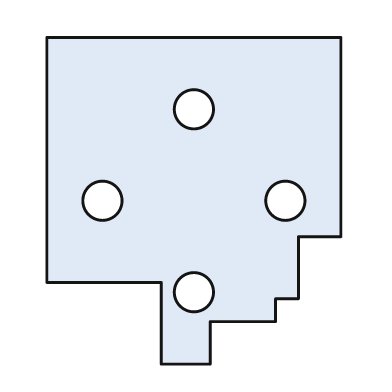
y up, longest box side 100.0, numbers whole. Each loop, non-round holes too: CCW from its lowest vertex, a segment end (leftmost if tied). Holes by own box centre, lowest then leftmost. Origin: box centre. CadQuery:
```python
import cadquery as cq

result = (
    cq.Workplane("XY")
    .moveTo(-10.0, -50.0)
    .lineTo(5.0, -50.0)
    .lineTo(5.0, -37.0)
    .lineTo(25.0, -37.0)
    .lineTo(25.0, -30.0)
    .lineTo(32.0, -30.0)
    .lineTo(32.0, -11.0)
    .lineTo(45.0, -11.0)
    .lineTo(45.0, 50.0)
    .lineTo(-45.0, 50.0)
    .lineTo(-45.0, -25.0)
    .lineTo(-10.0, -25.0)
    .close()
    .moveTo(0.0, -28.0)
    .circle(6.0)
    .moveTo(-28.0, 0.0)
    .circle(6.0)
    .moveTo(28.0, 0.0)
    .circle(6.0)
    .moveTo(0.0, 28.0)
    .circle(6.0)
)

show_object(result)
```